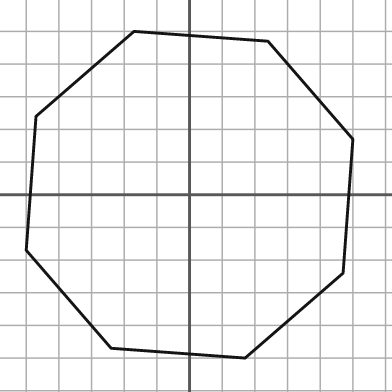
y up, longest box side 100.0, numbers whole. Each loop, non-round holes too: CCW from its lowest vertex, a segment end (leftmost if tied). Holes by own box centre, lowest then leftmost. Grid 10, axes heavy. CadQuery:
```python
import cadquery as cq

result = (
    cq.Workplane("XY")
    .moveTo(17.0, -50.0)
    .lineTo(47.0, -24.0)
    .lineTo(50.0, 17.0)
    .lineTo(24.0, 47.0)
    .lineTo(-17.0, 50.0)
    .lineTo(-47.0, 24.0)
    .lineTo(-50.0, -17.0)
    .lineTo(-24.0, -47.0)
    .close()
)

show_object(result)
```